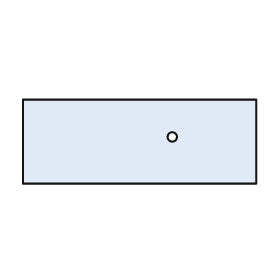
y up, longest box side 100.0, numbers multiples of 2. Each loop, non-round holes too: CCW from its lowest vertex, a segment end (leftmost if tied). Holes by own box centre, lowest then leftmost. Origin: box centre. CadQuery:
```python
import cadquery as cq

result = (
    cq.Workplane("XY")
    .moveTo(-50.0, -18.0)
    .lineTo(50.0, -18.0)
    .lineTo(50.0, 18.0)
    .lineTo(-50.0, 18.0)
    .close()
    .moveTo(14.0, 2.0)
    .circle(2.0)
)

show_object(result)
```